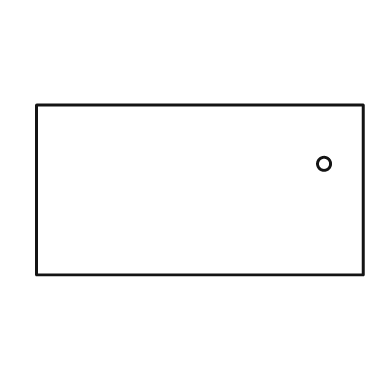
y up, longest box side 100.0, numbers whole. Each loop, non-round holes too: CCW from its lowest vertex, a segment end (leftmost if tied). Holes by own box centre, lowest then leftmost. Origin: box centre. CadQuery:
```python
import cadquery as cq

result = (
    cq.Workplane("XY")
    .moveTo(-50.0, -26.0)
    .lineTo(50.0, -26.0)
    .lineTo(50.0, 26.0)
    .lineTo(-50.0, 26.0)
    .close()
    .moveTo(38.0, 8.0)
    .circle(2.0)
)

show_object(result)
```